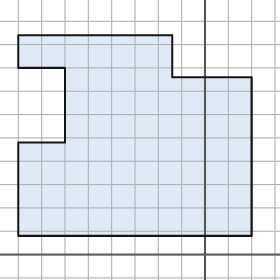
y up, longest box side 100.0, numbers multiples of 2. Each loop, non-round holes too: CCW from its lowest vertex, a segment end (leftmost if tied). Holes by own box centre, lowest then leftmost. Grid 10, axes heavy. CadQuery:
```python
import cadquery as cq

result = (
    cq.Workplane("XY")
    .moveTo(-80.0, 8.0)
    .lineTo(20.0, 8.0)
    .lineTo(20.0, 76.0)
    .lineTo(-14.0, 76.0)
    .lineTo(-14.0, 94.0)
    .lineTo(-80.0, 94.0)
    .lineTo(-80.0, 80.0)
    .lineTo(-60.0, 80.0)
    .lineTo(-60.0, 48.0)
    .lineTo(-80.0, 48.0)
    .close()
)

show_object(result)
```